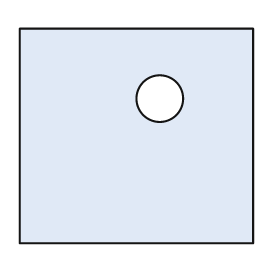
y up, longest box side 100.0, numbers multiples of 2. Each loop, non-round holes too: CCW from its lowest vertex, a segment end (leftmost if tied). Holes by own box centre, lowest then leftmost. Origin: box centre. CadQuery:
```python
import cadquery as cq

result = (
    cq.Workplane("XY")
    .moveTo(-50.0, -46.0)
    .lineTo(50.0, -46.0)
    .lineTo(50.0, 46.0)
    .lineTo(-50.0, 46.0)
    .close()
    .moveTo(10.0, 16.0)
    .circle(10.0)
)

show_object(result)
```